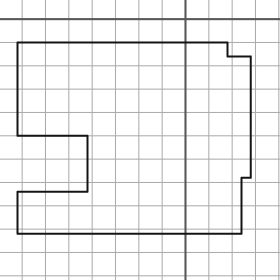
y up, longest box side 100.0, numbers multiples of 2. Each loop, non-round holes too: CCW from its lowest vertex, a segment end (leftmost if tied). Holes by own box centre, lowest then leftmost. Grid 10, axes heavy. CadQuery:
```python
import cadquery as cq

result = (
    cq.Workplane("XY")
    .moveTo(-72.0, -92.0)
    .lineTo(24.0, -92.0)
    .lineTo(24.0, -68.0)
    .lineTo(28.0, -68.0)
    .lineTo(28.0, -16.0)
    .lineTo(18.0, -16.0)
    .lineTo(18.0, -10.0)
    .lineTo(-72.0, -10.0)
    .lineTo(-72.0, -50.0)
    .lineTo(-42.0, -50.0)
    .lineTo(-42.0, -74.0)
    .lineTo(-72.0, -74.0)
    .close()
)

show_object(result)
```